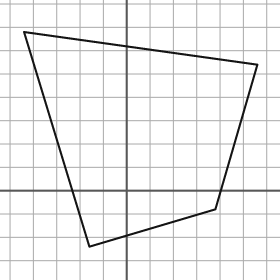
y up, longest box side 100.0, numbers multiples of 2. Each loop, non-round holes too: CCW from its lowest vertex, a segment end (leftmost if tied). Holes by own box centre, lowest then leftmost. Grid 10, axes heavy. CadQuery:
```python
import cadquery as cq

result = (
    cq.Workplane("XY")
    .moveTo(-16.0, -24.0)
    .lineTo(38.0, -8.0)
    .lineTo(56.0, 54.0)
    .lineTo(-44.0, 68.0)
    .close()
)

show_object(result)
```